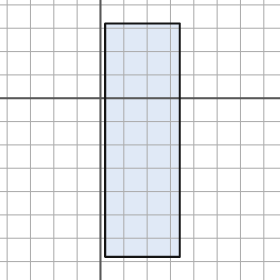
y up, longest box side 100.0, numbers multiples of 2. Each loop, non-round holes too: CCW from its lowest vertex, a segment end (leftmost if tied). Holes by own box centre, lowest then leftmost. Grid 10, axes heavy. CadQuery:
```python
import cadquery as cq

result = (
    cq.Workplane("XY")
    .moveTo(2.0, -68.0)
    .lineTo(34.0, -68.0)
    .lineTo(34.0, 32.0)
    .lineTo(2.0, 32.0)
    .close()
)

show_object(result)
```